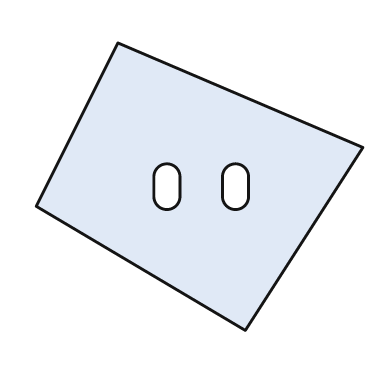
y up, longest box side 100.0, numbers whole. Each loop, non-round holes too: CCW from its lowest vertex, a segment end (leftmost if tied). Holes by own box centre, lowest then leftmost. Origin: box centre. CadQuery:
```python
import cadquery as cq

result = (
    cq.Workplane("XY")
    .moveTo(14.0, -44.0)
    .lineTo(50.0, 12.0)
    .lineTo(-25.0, 44.0)
    .lineTo(-50.0, -6.0)
    .close()
    .moveTo(-14.0, -3.0)
    .threePointArc((-10.0, -7.0), (-6.0, -3.0))
    .lineTo(-6.0, 3.0)
    .threePointArc((-10.0, 7.0), (-14.0, 3.0))
    .close()
    .moveTo(7.0, -3.0)
    .threePointArc((11.0, -7.0), (15.0, -3.0))
    .lineTo(15.0, 3.0)
    .threePointArc((11.0, 7.0), (7.0, 3.0))
    .close()
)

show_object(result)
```